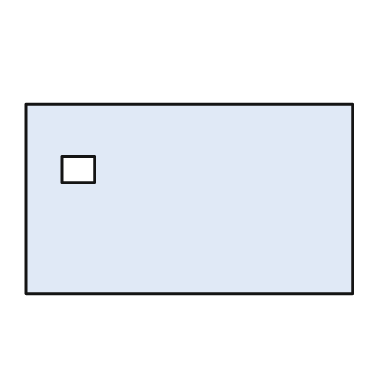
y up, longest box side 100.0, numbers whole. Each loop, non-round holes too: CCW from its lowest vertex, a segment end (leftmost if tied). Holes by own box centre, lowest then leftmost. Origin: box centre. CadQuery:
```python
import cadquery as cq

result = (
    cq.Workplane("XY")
    .moveTo(-50.0, -29.0)
    .lineTo(50.0, -29.0)
    .lineTo(50.0, 29.0)
    .lineTo(-50.0, 29.0)
    .close()
    .moveTo(-39.0, 5.0)
    .lineTo(-29.0, 5.0)
    .lineTo(-29.0, 13.0)
    .lineTo(-39.0, 13.0)
    .close()
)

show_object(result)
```